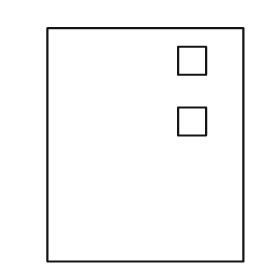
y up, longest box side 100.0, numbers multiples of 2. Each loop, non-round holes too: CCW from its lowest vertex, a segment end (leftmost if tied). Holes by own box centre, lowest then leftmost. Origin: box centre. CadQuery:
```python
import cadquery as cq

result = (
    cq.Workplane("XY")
    .moveTo(-42.0, -50.0)
    .lineTo(42.0, -50.0)
    .lineTo(42.0, 50.0)
    .lineTo(-42.0, 50.0)
    .close()
    .moveTo(14.0, 4.0)
    .lineTo(26.0, 4.0)
    .lineTo(26.0, 16.0)
    .lineTo(14.0, 16.0)
    .close()
    .moveTo(14.0, 30.0)
    .lineTo(26.0, 30.0)
    .lineTo(26.0, 42.0)
    .lineTo(14.0, 42.0)
    .close()
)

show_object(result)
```